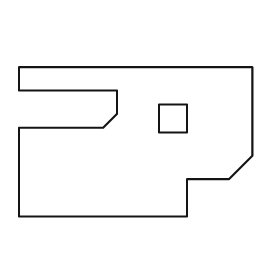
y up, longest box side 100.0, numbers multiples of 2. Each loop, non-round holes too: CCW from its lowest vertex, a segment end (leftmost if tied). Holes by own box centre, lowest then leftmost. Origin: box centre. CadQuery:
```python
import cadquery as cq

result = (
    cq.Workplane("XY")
    .moveTo(-50.0, -32.0)
    .lineTo(22.0, -32.0)
    .lineTo(22.0, -16.0)
    .lineTo(40.0, -16.0)
    .lineTo(50.0, -6.0)
    .lineTo(50.0, 32.0)
    .lineTo(-50.0, 32.0)
    .lineTo(-50.0, 22.0)
    .lineTo(-8.0, 22.0)
    .lineTo(-8.0, 12.0)
    .lineTo(-14.0, 6.0)
    .lineTo(-50.0, 6.0)
    .close()
    .moveTo(10.0, 4.0)
    .lineTo(22.0, 4.0)
    .lineTo(22.0, 16.0)
    .lineTo(10.0, 16.0)
    .close()
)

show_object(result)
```